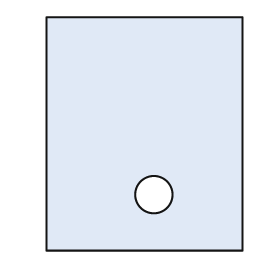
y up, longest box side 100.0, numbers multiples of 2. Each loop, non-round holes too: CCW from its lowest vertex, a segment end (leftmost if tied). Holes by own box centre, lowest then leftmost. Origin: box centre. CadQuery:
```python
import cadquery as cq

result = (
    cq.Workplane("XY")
    .moveTo(-42.0, -50.0)
    .lineTo(42.0, -50.0)
    .lineTo(42.0, 50.0)
    .lineTo(-42.0, 50.0)
    .close()
    .moveTo(4.0, -26.0)
    .circle(8.0)
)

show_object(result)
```